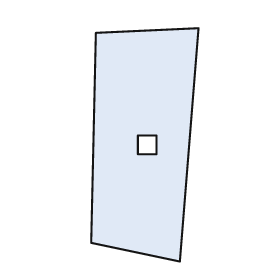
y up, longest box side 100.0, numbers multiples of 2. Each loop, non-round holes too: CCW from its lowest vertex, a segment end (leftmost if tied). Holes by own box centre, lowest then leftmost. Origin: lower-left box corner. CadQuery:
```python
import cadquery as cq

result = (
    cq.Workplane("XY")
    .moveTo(38.0, 0.0)
    .lineTo(46.0, 100.0)
    .lineTo(2.0, 98.0)
    .lineTo(0.0, 8.0)
    .close()
    .moveTo(20.0, 46.0)
    .lineTo(28.0, 46.0)
    .lineTo(28.0, 54.0)
    .lineTo(20.0, 54.0)
    .close()
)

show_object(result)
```